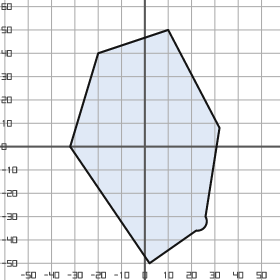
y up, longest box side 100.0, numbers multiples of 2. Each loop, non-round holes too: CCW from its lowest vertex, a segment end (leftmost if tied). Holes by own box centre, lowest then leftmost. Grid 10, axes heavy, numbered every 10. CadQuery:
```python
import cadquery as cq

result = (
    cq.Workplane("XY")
    .moveTo(2.0, -50.0)
    .lineTo(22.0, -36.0)
    .threePointArc((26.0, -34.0), (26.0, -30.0))
    .lineTo(32.0, 8.0)
    .lineTo(10.0, 50.0)
    .lineTo(-20.0, 40.0)
    .lineTo(-32.0, 0.0)
    .close()
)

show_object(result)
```